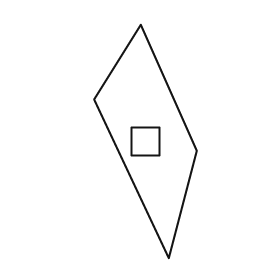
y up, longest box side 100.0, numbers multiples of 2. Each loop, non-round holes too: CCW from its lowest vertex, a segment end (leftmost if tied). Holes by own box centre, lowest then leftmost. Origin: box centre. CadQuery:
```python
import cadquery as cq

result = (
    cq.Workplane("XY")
    .moveTo(10.0, -50.0)
    .lineTo(22.0, -4.0)
    .lineTo(-2.0, 50.0)
    .lineTo(-22.0, 18.0)
    .close()
    .moveTo(-6.0, -6.0)
    .lineTo(6.0, -6.0)
    .lineTo(6.0, 6.0)
    .lineTo(-6.0, 6.0)
    .close()
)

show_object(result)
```